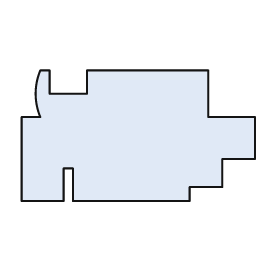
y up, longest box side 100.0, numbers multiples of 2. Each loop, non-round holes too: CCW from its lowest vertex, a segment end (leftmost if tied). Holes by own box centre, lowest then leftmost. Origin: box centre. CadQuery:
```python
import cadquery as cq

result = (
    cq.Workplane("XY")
    .moveTo(-50.0, -28.0)
    .lineTo(-32.0, -28.0)
    .lineTo(-32.0, -14.0)
    .lineTo(-28.0, -14.0)
    .lineTo(-28.0, -28.0)
    .lineTo(22.0, -28.0)
    .lineTo(22.0, -22.0)
    .lineTo(36.0, -22.0)
    .lineTo(36.0, -10.0)
    .lineTo(50.0, -10.0)
    .lineTo(50.0, 8.0)
    .lineTo(30.0, 8.0)
    .lineTo(30.0, 28.0)
    .lineTo(-22.0, 28.0)
    .lineTo(-22.0, 18.0)
    .lineTo(-38.0, 18.0)
    .lineTo(-38.0, 28.0)
    .lineTo(-42.0, 28.0)
    .threePointArc((-44.0, 18.0), (-42.0, 8.0))
    .lineTo(-50.0, 8.0)
    .close()
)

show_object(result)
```